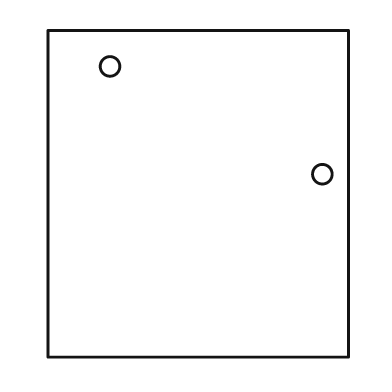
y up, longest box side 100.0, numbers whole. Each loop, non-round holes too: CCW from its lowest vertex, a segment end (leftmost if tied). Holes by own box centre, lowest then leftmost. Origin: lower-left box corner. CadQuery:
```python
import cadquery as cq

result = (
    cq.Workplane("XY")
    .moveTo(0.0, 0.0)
    .lineTo(92.0, 0.0)
    .lineTo(92.0, 100.0)
    .lineTo(0.0, 100.0)
    .close()
    .moveTo(84.0, 56.0)
    .circle(3.0)
    .moveTo(19.0, 89.0)
    .circle(3.0)
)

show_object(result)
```